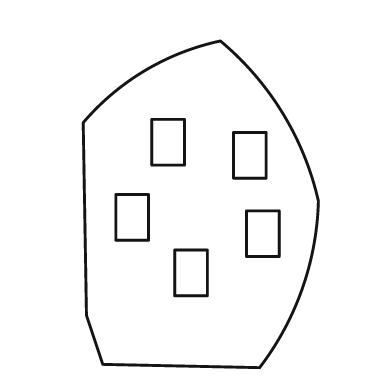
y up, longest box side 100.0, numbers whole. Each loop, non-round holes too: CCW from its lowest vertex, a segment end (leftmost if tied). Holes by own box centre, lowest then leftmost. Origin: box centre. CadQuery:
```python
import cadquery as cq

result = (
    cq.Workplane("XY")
    .moveTo(18.0, -50.0)
    .threePointArc((31.0, -26.0), (36.0, 1.0))
    .threePointArc((25.0, 28.0), (6.0, 50.0))
    .threePointArc((-17.0, 41.0), (-36.0, 25.0))
    .lineTo(-35.0, -34.0)
    .lineTo(-30.0, -49.0)
    .close()
    .moveTo(-8.0, -28.0)
    .lineTo(2.0, -28.0)
    .lineTo(2.0, -14.0)
    .lineTo(-8.0, -14.0)
    .close()
    .moveTo(14.0, -16.0)
    .lineTo(24.0, -16.0)
    .lineTo(24.0, -2.0)
    .lineTo(14.0, -2.0)
    .close()
    .moveTo(-26.0, -11.0)
    .lineTo(-16.0, -11.0)
    .lineTo(-16.0, 3.0)
    .lineTo(-26.0, 3.0)
    .close()
    .moveTo(10.0, 8.0)
    .lineTo(20.0, 8.0)
    .lineTo(20.0, 22.0)
    .lineTo(10.0, 22.0)
    .close()
    .moveTo(-15.0, 12.0)
    .lineTo(-5.0, 12.0)
    .lineTo(-5.0, 26.0)
    .lineTo(-15.0, 26.0)
    .close()
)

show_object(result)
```